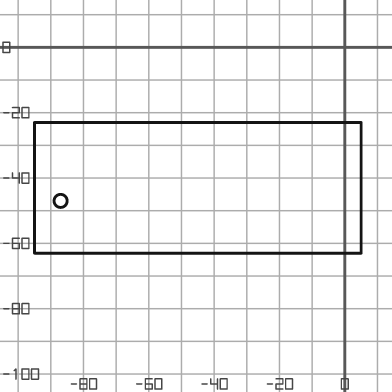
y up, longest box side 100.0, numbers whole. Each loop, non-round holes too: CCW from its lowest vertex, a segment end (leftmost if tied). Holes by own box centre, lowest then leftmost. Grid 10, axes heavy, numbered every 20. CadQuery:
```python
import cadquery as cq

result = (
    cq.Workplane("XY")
    .moveTo(-95.0, -63.0)
    .lineTo(5.0, -63.0)
    .lineTo(5.0, -23.0)
    .lineTo(-95.0, -23.0)
    .close()
    .moveTo(-87.0, -47.0)
    .circle(2.0)
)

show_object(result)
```